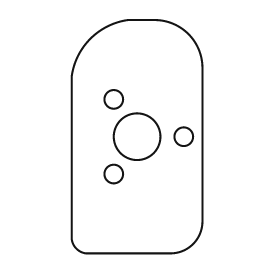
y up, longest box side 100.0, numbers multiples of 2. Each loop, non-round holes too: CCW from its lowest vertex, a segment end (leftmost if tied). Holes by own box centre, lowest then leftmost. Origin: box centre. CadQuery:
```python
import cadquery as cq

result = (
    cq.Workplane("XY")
    .moveTo(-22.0, -50.0)
    .lineTo(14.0, -50.0)
    .threePointArc((24.0, -46.0), (28.0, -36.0))
    .lineTo(28.0, 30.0)
    .threePointArc((22.0, 44.0), (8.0, 50.0))
    .lineTo(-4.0, 50.0)
    .threePointArc((-20.0, 42.0), (-28.0, 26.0))
    .lineTo(-28.0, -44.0)
    .threePointArc((-26.0, -48.0), (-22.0, -50.0))
    .close()
    .moveTo(-10.0, -16.0)
    .circle(4.0)
    .moveTo(0.0, 0.0)
    .circle(10.0)
    .moveTo(20.0, 0.0)
    .circle(4.0)
    .moveTo(-10.0, 16.0)
    .circle(4.0)
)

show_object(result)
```